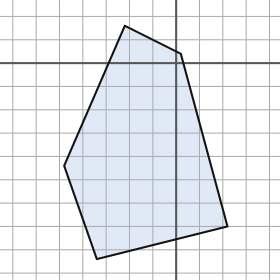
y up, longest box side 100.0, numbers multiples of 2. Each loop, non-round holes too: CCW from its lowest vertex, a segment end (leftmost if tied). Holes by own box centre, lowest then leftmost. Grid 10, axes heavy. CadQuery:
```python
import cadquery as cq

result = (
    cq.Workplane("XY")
    .moveTo(-34.0, -84.0)
    .lineTo(22.0, -70.0)
    .lineTo(2.0, 4.0)
    .lineTo(-22.0, 16.0)
    .lineTo(-48.0, -44.0)
    .close()
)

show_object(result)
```